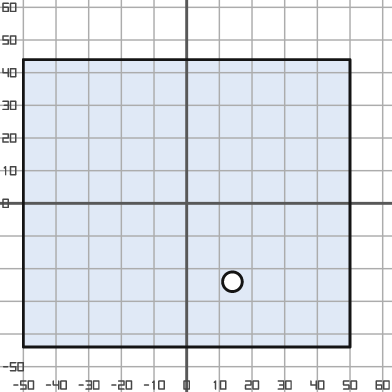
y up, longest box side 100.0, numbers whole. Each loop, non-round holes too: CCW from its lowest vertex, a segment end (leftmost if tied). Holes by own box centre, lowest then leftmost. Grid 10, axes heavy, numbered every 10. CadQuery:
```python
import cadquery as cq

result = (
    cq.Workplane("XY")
    .moveTo(-50.0, -44.0)
    .lineTo(50.0, -44.0)
    .lineTo(50.0, 44.0)
    .lineTo(-50.0, 44.0)
    .close()
    .moveTo(14.0, -24.0)
    .circle(3.0)
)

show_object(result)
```